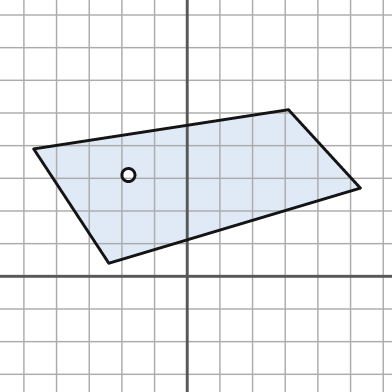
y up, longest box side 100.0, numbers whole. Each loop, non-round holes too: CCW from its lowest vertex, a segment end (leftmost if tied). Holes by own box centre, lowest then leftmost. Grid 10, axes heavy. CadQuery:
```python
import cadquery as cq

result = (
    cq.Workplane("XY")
    .moveTo(-24.0, 4.0)
    .lineTo(53.0, 27.0)
    .lineTo(31.0, 51.0)
    .lineTo(-47.0, 39.0)
    .close()
    .moveTo(-18.0, 31.0)
    .circle(2.0)
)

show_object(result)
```